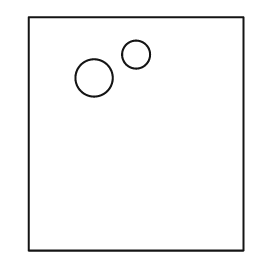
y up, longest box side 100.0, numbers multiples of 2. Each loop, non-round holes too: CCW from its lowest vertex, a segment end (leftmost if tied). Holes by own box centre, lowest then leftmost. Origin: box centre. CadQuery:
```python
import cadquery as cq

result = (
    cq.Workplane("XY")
    .moveTo(-46.0, -50.0)
    .lineTo(46.0, -50.0)
    .lineTo(46.0, 50.0)
    .lineTo(-46.0, 50.0)
    .close()
    .moveTo(-18.0, 24.0)
    .circle(8.0)
    .moveTo(0.0, 34.0)
    .circle(6.0)
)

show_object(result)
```